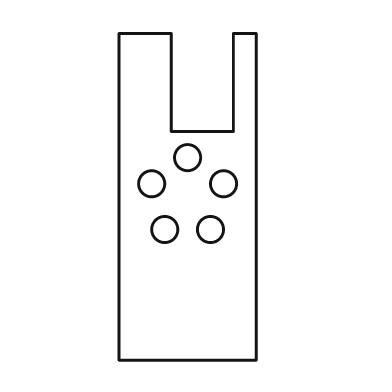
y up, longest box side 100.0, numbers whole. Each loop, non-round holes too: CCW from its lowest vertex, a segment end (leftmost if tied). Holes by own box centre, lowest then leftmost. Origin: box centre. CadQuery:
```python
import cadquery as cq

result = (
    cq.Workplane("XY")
    .moveTo(-21.0, -50.0)
    .lineTo(21.0, -50.0)
    .lineTo(21.0, 50.0)
    .lineTo(14.0, 50.0)
    .lineTo(14.0, 20.0)
    .lineTo(-5.0, 20.0)
    .lineTo(-5.0, 50.0)
    .lineTo(-21.0, 50.0)
    .close()
    .moveTo(-7.0, -10.0)
    .circle(4.0)
    .moveTo(7.0, -10.0)
    .circle(4.0)
    .moveTo(-11.0, 4.0)
    .circle(4.0)
    .moveTo(11.0, 4.0)
    .circle(4.0)
    .moveTo(0.0, 12.0)
    .circle(4.0)
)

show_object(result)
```